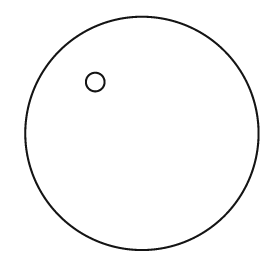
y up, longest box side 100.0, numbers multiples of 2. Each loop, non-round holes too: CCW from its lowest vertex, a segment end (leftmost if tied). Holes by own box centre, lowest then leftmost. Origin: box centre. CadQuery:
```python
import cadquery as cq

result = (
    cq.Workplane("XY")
    .moveTo(0.0, 0.0)
    .circle(50.0)
    .moveTo(-20.0, 22.0)
    .circle(4.0)
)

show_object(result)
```